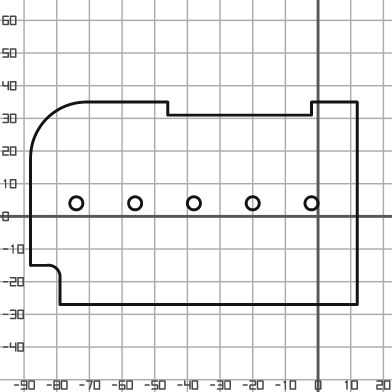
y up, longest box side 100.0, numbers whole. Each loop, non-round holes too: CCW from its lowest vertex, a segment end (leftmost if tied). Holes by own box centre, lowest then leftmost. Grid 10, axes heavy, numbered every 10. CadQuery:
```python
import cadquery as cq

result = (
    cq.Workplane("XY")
    .moveTo(-79.0, -27.0)
    .lineTo(12.0, -27.0)
    .lineTo(12.0, 35.0)
    .lineTo(-2.0, 35.0)
    .lineTo(-2.0, 31.0)
    .lineTo(-46.0, 31.0)
    .lineTo(-46.0, 35.0)
    .lineTo(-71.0, 35.0)
    .threePointArc((-83.0, 30.0), (-88.0, 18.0))
    .lineTo(-88.0, -15.0)
    .lineTo(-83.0, -15.0)
    .threePointArc((-80.0, -16.0), (-79.0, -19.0))
    .close()
    .moveTo(-74.0, 4.0)
    .circle(2.0)
    .moveTo(-56.0, 4.0)
    .circle(2.0)
    .moveTo(-38.0, 4.0)
    .circle(2.0)
    .moveTo(-20.0, 4.0)
    .circle(2.0)
    .moveTo(-2.0, 4.0)
    .circle(2.0)
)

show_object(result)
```